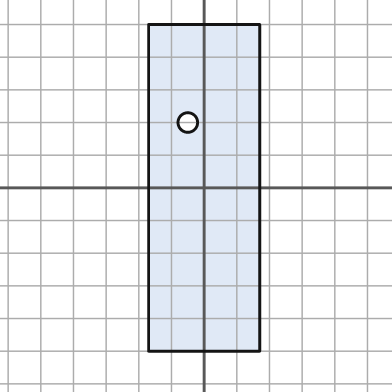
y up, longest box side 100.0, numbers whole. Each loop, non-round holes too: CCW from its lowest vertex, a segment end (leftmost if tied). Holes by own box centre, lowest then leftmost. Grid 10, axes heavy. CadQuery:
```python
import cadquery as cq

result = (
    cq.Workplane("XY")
    .moveTo(-17.0, -50.0)
    .lineTo(17.0, -50.0)
    .lineTo(17.0, 50.0)
    .lineTo(-17.0, 50.0)
    .close()
    .moveTo(-5.0, 20.0)
    .circle(3.0)
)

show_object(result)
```